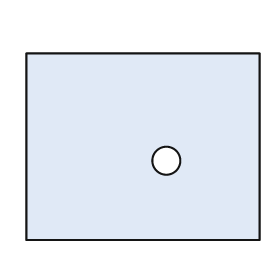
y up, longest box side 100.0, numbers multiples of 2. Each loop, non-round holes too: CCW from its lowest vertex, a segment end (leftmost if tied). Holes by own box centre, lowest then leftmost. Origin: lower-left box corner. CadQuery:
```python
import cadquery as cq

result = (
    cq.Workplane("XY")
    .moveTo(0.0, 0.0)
    .lineTo(100.0, 0.0)
    .lineTo(100.0, 80.0)
    .lineTo(0.0, 80.0)
    .close()
    .moveTo(60.0, 34.0)
    .circle(6.0)
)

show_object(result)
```